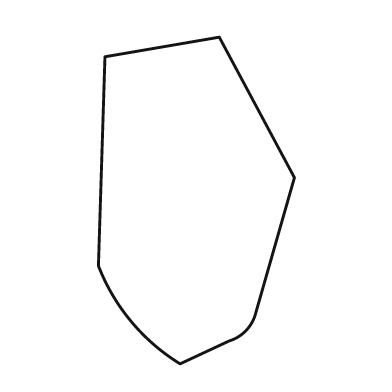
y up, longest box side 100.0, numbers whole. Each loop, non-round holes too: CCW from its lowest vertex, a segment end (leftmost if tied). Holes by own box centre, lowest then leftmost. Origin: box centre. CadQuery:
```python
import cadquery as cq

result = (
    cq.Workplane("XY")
    .moveTo(-5.0, -50.0)
    .lineTo(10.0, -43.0)
    .threePointArc((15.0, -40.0), (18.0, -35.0))
    .lineTo(30.0, 7.0)
    .lineTo(7.0, 50.0)
    .lineTo(-28.0, 44.0)
    .lineTo(-30.0, -20.0)
    .threePointArc((-20.0, -37.0), (-5.0, -50.0))
    .close()
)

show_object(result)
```